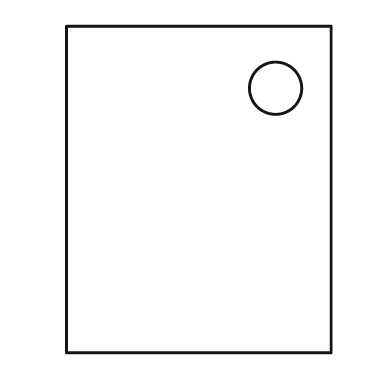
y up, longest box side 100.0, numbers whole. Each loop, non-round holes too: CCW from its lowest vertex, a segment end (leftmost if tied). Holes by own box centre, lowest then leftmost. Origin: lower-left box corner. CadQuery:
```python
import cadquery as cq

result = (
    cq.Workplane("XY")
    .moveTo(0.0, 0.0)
    .lineTo(81.0, 0.0)
    .lineTo(81.0, 100.0)
    .lineTo(0.0, 100.0)
    .close()
    .moveTo(64.0, 81.0)
    .circle(8.0)
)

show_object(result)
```